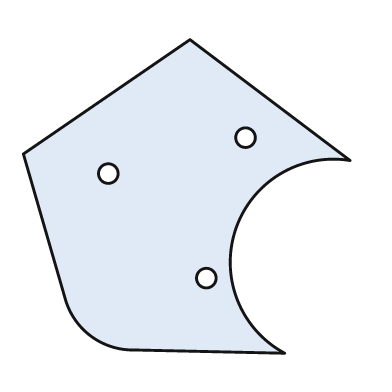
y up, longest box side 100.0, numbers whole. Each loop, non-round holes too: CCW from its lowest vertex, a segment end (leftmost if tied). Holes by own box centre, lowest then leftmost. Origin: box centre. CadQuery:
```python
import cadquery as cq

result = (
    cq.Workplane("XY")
    .moveTo(30.0, -48.0)
    .threePointArc((15.0, -10.0), (50.0, 11.0))
    .lineTo(1.0, 48.0)
    .lineTo(-50.0, 13.0)
    .lineTo(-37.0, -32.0)
    .threePointArc((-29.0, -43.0), (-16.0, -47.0))
    .close()
    .moveTo(6.0, -25.0)
    .circle(3.0)
    .moveTo(-24.0, 7.0)
    .circle(3.0)
    .moveTo(18.0, 18.0)
    .circle(3.0)
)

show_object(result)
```